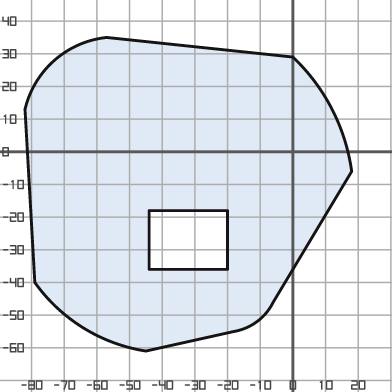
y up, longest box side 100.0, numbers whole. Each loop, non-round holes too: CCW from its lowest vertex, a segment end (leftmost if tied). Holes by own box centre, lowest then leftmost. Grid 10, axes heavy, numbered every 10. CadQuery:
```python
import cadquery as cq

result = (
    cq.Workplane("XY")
    .moveTo(-45.0, -61.0)
    .lineTo(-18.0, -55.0)
    .threePointArc((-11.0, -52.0), (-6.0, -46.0))
    .lineTo(18.0, -6.0)
    .threePointArc((12.0, 13.0), (0.0, 29.0))
    .lineTo(-57.0, 35.0)
    .threePointArc((-73.0, 28.0), (-82.0, 13.0))
    .lineTo(-79.0, -40.0)
    .threePointArc((-64.0, -54.0), (-45.0, -61.0))
    .close()
    .moveTo(-44.0, -36.0)
    .lineTo(-20.0, -36.0)
    .lineTo(-20.0, -18.0)
    .lineTo(-44.0, -18.0)
    .close()
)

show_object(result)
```